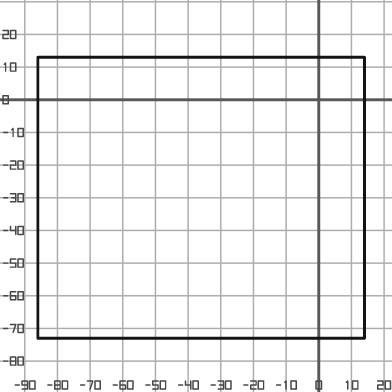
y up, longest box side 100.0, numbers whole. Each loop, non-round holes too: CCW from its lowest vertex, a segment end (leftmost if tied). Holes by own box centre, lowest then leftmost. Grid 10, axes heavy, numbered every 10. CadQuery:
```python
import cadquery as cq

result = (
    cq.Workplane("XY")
    .moveTo(-86.0, -73.0)
    .lineTo(14.0, -73.0)
    .lineTo(14.0, 13.0)
    .lineTo(-86.0, 13.0)
    .close()
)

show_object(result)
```